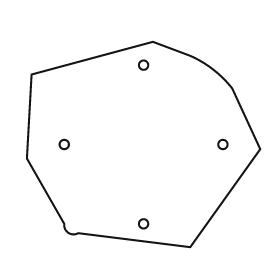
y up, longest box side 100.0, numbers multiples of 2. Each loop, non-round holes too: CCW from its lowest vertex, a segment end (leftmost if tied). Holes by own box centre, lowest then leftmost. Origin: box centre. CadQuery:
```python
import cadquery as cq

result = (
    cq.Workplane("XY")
    .moveTo(20.0, -44.0)
    .lineTo(50.0, -2.0)
    .lineTo(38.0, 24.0)
    .threePointArc((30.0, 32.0), (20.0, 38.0))
    .lineTo(4.0, 44.0)
    .lineTo(-48.0, 30.0)
    .lineTo(-50.0, -6.0)
    .lineTo(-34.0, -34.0)
    .threePointArc((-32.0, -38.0), (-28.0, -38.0))
    .close()
    .moveTo(0.0, -34.0)
    .circle(2.0)
    .moveTo(-34.0, 0.0)
    .circle(2.0)
    .moveTo(34.0, 0.0)
    .circle(2.0)
    .moveTo(0.0, 34.0)
    .circle(2.0)
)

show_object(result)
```